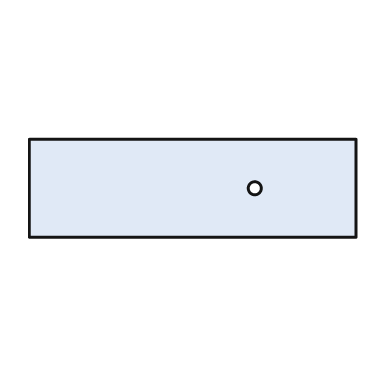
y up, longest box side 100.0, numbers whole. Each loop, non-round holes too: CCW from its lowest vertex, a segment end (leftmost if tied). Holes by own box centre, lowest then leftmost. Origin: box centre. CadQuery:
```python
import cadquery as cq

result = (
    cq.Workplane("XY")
    .moveTo(-50.0, -15.0)
    .lineTo(50.0, -15.0)
    .lineTo(50.0, 15.0)
    .lineTo(-50.0, 15.0)
    .close()
    .moveTo(19.0, 0.0)
    .circle(2.0)
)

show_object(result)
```